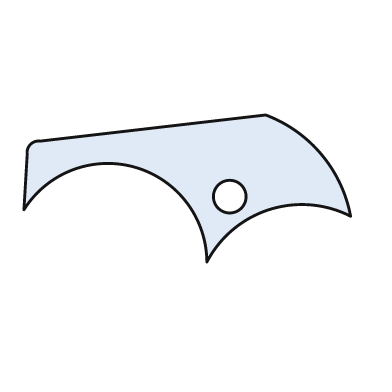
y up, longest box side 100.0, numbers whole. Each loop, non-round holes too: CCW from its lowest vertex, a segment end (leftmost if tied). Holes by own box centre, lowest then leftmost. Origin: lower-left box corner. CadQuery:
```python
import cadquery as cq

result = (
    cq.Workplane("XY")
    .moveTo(56.0, 0.0)
    .threePointArc((75.0, 16.0), (100.0, 14.0))
    .threePointArc((91.0, 33.0), (74.0, 45.0))
    .lineTo(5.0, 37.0)
    .threePointArc((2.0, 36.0), (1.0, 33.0))
    .lineTo(0.0, 16.0)
    .threePointArc((34.0, 29.0), (56.0, 0.0))
    .close()
    .moveTo(63.0, 20.0)
    .circle(5.0)
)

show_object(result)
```